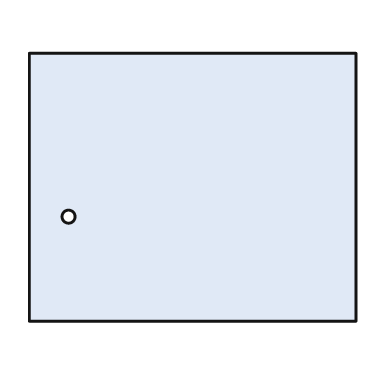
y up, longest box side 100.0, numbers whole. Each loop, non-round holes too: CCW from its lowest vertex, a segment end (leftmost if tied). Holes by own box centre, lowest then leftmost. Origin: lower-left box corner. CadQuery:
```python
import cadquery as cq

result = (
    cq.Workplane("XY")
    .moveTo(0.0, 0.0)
    .lineTo(100.0, 0.0)
    .lineTo(100.0, 82.0)
    .lineTo(0.0, 82.0)
    .close()
    .moveTo(12.0, 32.0)
    .circle(2.0)
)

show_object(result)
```